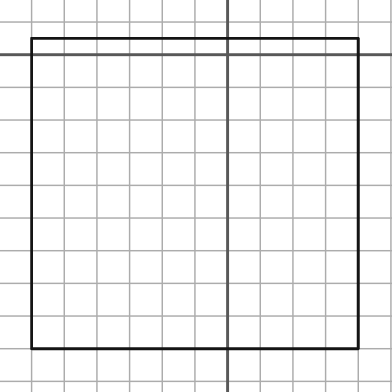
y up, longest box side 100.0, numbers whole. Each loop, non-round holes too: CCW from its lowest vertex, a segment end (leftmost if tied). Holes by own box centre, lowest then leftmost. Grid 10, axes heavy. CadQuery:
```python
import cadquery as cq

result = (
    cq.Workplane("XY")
    .moveTo(-60.0, -90.0)
    .lineTo(40.0, -90.0)
    .lineTo(40.0, 5.0)
    .lineTo(-60.0, 5.0)
    .close()
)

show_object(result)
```